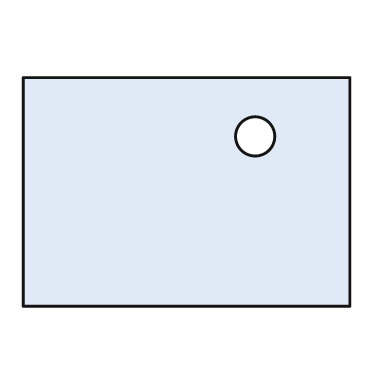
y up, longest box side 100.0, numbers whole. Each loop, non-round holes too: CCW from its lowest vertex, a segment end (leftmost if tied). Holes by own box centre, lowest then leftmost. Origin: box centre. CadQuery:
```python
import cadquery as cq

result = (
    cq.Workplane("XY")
    .moveTo(-50.0, -35.0)
    .lineTo(50.0, -35.0)
    .lineTo(50.0, 35.0)
    .lineTo(-50.0, 35.0)
    .close()
    .moveTo(21.0, 17.0)
    .circle(6.0)
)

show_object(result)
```